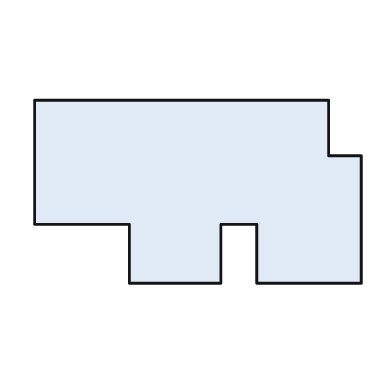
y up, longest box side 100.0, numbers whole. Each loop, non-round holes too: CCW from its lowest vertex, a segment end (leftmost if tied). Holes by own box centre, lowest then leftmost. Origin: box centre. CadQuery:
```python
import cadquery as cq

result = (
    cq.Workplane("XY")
    .moveTo(-21.0, -28.0)
    .lineTo(7.0, -28.0)
    .lineTo(7.0, -10.0)
    .lineTo(18.0, -10.0)
    .lineTo(18.0, -28.0)
    .lineTo(50.0, -28.0)
    .lineTo(50.0, 11.0)
    .lineTo(40.0, 11.0)
    .lineTo(40.0, 28.0)
    .lineTo(-50.0, 28.0)
    .lineTo(-50.0, -10.0)
    .lineTo(-21.0, -10.0)
    .close()
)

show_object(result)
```